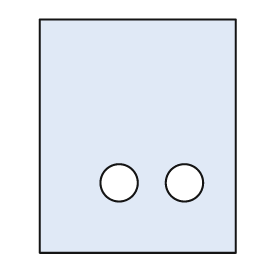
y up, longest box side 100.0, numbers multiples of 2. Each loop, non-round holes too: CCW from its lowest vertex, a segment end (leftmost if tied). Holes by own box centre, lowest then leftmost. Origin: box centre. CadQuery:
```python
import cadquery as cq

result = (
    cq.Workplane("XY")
    .moveTo(-42.0, -50.0)
    .lineTo(42.0, -50.0)
    .lineTo(42.0, 50.0)
    .lineTo(-42.0, 50.0)
    .close()
    .moveTo(-8.0, -20.0)
    .circle(8.0)
    .moveTo(20.0, -20.0)
    .circle(8.0)
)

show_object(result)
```